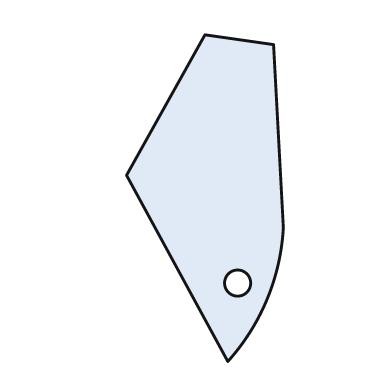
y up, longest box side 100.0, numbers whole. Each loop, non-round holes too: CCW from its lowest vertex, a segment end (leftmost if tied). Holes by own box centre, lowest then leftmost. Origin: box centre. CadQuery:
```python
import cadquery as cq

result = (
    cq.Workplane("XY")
    .moveTo(7.0, -50.0)
    .threePointArc((19.0, -31.0), (24.0, -9.0))
    .lineTo(21.0, 47.0)
    .lineTo(0.0, 50.0)
    .lineTo(-24.0, 7.0)
    .close()
    .moveTo(10.0, -26.0)
    .circle(4.0)
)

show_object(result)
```